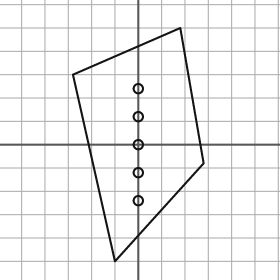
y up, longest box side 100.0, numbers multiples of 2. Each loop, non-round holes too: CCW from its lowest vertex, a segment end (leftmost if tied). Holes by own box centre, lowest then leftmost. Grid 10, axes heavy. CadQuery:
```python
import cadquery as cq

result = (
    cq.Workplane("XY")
    .moveTo(-10.0, -50.0)
    .lineTo(28.0, -8.0)
    .lineTo(18.0, 50.0)
    .lineTo(-28.0, 30.0)
    .close()
    .moveTo(0.0, -24.0)
    .circle(2.0)
    .moveTo(0.0, -12.0)
    .circle(2.0)
    .moveTo(0.0, 0.0)
    .circle(2.0)
    .moveTo(0.0, 12.0)
    .circle(2.0)
    .moveTo(0.0, 24.0)
    .circle(2.0)
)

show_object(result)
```